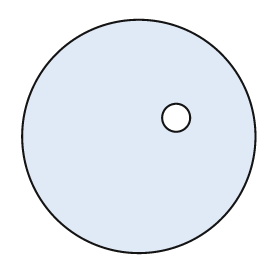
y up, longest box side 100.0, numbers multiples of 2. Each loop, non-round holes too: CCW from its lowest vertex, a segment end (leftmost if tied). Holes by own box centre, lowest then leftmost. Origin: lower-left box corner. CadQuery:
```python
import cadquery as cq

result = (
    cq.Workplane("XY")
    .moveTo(50.0, 50.0)
    .circle(50.0)
    .moveTo(66.0, 58.0)
    .circle(6.0)
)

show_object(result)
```